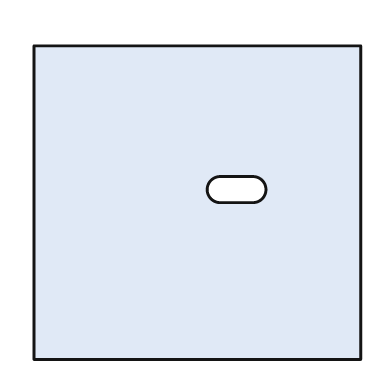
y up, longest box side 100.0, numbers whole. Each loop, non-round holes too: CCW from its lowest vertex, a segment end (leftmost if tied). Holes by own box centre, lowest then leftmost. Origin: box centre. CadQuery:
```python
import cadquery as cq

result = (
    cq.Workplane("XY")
    .moveTo(-50.0, -48.0)
    .lineTo(50.0, -48.0)
    .lineTo(50.0, 48.0)
    .lineTo(-50.0, 48.0)
    .close()
    .moveTo(7.0, 0.0)
    .lineTo(17.0, 0.0)
    .threePointArc((21.0, 4.0), (17.0, 8.0))
    .lineTo(7.0, 8.0)
    .threePointArc((3.0, 4.0), (7.0, 0.0))
    .close()
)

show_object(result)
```